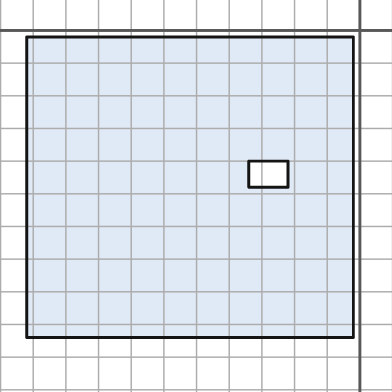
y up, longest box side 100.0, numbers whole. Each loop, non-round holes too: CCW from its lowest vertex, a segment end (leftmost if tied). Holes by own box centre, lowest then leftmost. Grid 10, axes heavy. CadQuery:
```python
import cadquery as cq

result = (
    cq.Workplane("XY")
    .moveTo(-102.0, -94.0)
    .lineTo(-2.0, -94.0)
    .lineTo(-2.0, -2.0)
    .lineTo(-102.0, -2.0)
    .close()
    .moveTo(-34.0, -48.0)
    .lineTo(-22.0, -48.0)
    .lineTo(-22.0, -40.0)
    .lineTo(-34.0, -40.0)
    .close()
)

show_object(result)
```